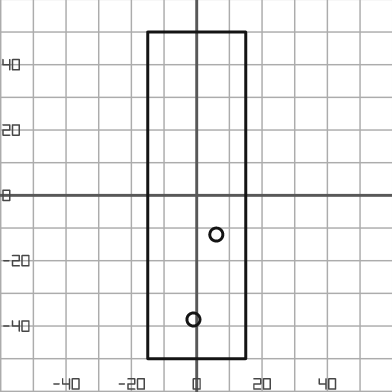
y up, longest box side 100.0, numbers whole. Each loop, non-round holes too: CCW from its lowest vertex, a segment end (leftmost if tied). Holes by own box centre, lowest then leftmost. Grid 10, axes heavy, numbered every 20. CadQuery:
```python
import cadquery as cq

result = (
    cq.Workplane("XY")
    .moveTo(-15.0, -50.0)
    .lineTo(15.0, -50.0)
    .lineTo(15.0, 50.0)
    .lineTo(-15.0, 50.0)
    .close()
    .moveTo(-1.0, -38.0)
    .circle(2.0)
    .moveTo(6.0, -12.0)
    .circle(2.0)
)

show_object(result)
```